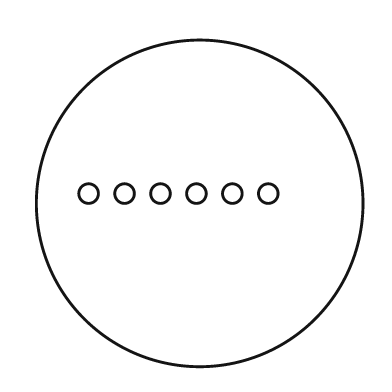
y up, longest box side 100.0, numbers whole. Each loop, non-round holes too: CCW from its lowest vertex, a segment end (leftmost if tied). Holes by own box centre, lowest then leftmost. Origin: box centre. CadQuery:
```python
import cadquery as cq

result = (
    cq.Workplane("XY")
    .moveTo(0.0, 0.0)
    .circle(50.0)
    .moveTo(-34.0, 3.0)
    .circle(3.0)
    .moveTo(-23.0, 3.0)
    .circle(3.0)
    .moveTo(-12.0, 3.0)
    .circle(3.0)
    .moveTo(-1.0, 3.0)
    .circle(3.0)
    .moveTo(10.0, 3.0)
    .circle(3.0)
    .moveTo(21.0, 3.0)
    .circle(3.0)
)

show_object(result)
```